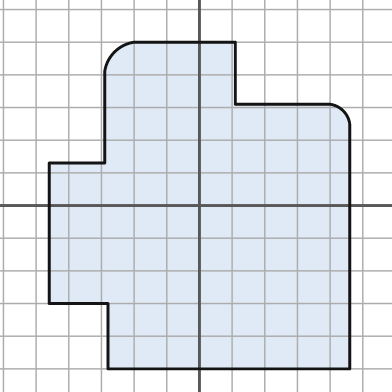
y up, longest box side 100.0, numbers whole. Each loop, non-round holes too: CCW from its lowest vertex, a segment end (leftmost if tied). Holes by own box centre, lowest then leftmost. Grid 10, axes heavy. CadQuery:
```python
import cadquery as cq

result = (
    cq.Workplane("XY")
    .moveTo(-28.0, -50.0)
    .lineTo(46.0, -50.0)
    .lineTo(46.0, 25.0)
    .threePointArc((44.0, 29.0), (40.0, 31.0))
    .lineTo(11.0, 31.0)
    .lineTo(11.0, 50.0)
    .lineTo(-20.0, 50.0)
    .threePointArc((-26.0, 47.0), (-29.0, 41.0))
    .lineTo(-29.0, 13.0)
    .lineTo(-46.0, 13.0)
    .lineTo(-46.0, -30.0)
    .lineTo(-28.0, -30.0)
    .close()
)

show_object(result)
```